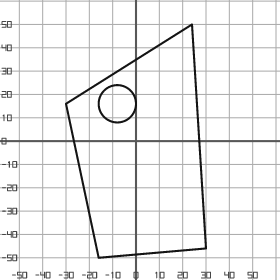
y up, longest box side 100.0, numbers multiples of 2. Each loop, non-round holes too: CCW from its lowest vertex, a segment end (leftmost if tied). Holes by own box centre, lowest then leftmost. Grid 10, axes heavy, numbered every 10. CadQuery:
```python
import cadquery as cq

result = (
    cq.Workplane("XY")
    .moveTo(-16.0, -50.0)
    .lineTo(30.0, -46.0)
    .lineTo(24.0, 50.0)
    .lineTo(-30.0, 16.0)
    .close()
    .moveTo(-8.0, 16.0)
    .circle(8.0)
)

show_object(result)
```